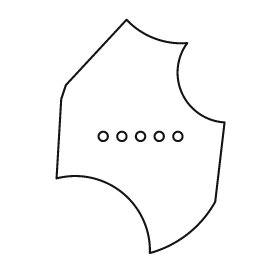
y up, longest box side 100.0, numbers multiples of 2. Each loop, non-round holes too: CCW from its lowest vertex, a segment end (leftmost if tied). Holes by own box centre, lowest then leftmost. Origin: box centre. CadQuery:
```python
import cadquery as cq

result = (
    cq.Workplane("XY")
    .moveTo(4.0, -50.0)
    .threePointArc((20.0, -42.0), (32.0, -28.0))
    .lineTo(36.0, 6.0)
    .threePointArc((18.0, 18.0), (20.0, 40.0))
    .threePointArc((6.0, 42.0), (-6.0, 50.0))
    .lineTo(-32.0, 22.0)
    .lineTo(-34.0, 16.0)
    .lineTo(-36.0, -18.0)
    .threePointArc((-8.0, -24.0), (4.0, -50.0))
    .close()
    .moveTo(-16.0, 0.0)
    .circle(2.0)
    .moveTo(-8.0, 0.0)
    .circle(2.0)
    .moveTo(0.0, 0.0)
    .circle(2.0)
    .moveTo(8.0, 0.0)
    .circle(2.0)
    .moveTo(16.0, 0.0)
    .circle(2.0)
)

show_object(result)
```